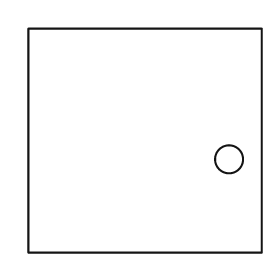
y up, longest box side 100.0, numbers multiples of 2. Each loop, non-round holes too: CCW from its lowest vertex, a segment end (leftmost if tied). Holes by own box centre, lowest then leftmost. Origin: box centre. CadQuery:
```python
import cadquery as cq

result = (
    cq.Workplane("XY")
    .moveTo(-50.0, -48.0)
    .lineTo(50.0, -48.0)
    .lineTo(50.0, 48.0)
    .lineTo(-50.0, 48.0)
    .close()
    .moveTo(36.0, -8.0)
    .circle(6.0)
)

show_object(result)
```